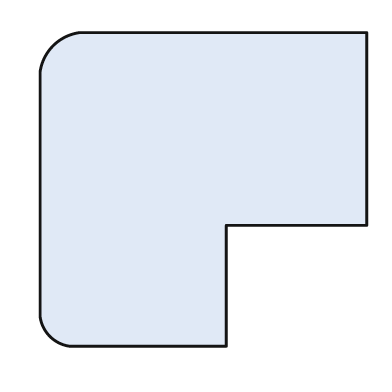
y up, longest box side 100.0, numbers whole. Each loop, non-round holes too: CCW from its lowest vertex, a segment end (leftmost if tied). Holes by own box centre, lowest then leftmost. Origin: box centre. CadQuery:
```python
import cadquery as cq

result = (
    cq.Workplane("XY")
    .moveTo(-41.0, -48.0)
    .lineTo(7.0, -48.0)
    .lineTo(7.0, -11.0)
    .lineTo(50.0, -11.0)
    .lineTo(50.0, 48.0)
    .lineTo(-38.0, 48.0)
    .threePointArc((-46.0, 44.0), (-50.0, 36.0))
    .lineTo(-50.0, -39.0)
    .threePointArc((-47.0, -45.0), (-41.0, -48.0))
    .close()
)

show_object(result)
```